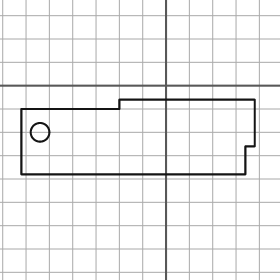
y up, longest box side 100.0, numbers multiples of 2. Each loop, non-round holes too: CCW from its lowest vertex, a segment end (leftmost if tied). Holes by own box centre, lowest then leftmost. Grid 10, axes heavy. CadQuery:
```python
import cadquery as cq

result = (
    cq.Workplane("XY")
    .moveTo(-62.0, -38.0)
    .lineTo(34.0, -38.0)
    .lineTo(34.0, -26.0)
    .lineTo(38.0, -26.0)
    .lineTo(38.0, -6.0)
    .lineTo(-20.0, -6.0)
    .lineTo(-20.0, -10.0)
    .lineTo(-62.0, -10.0)
    .close()
    .moveTo(-54.0, -20.0)
    .circle(4.0)
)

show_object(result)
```